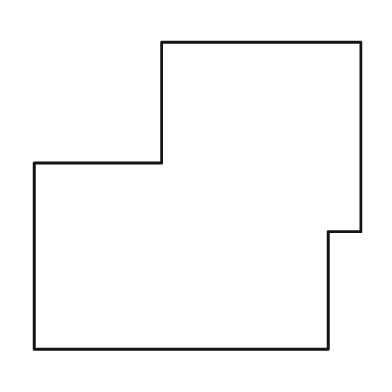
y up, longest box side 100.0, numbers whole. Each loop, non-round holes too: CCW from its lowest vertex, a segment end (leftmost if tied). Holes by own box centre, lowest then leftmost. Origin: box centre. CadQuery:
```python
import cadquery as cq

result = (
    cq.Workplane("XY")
    .moveTo(-50.0, -47.0)
    .lineTo(40.0, -47.0)
    .lineTo(40.0, -11.0)
    .lineTo(50.0, -11.0)
    .lineTo(50.0, 47.0)
    .lineTo(-11.0, 47.0)
    .lineTo(-11.0, 10.0)
    .lineTo(-50.0, 10.0)
    .close()
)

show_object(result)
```